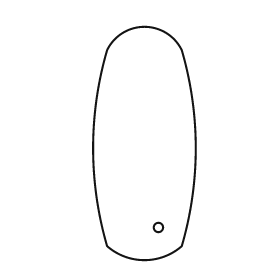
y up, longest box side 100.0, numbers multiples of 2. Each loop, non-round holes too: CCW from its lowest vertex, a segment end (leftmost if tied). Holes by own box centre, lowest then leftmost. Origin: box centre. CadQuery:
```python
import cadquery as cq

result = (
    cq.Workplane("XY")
    .moveTo(-16.0, -44.0)
    .threePointArc((0.0, -50.0), (16.0, -44.0))
    .threePointArc((22.0, -2.0), (16.0, 40.0))
    .threePointArc((0.0, 50.0), (-16.0, 40.0))
    .threePointArc((-22.0, -2.0), (-16.0, -44.0))
    .close()
    .moveTo(6.0, -36.0)
    .circle(2.0)
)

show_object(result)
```